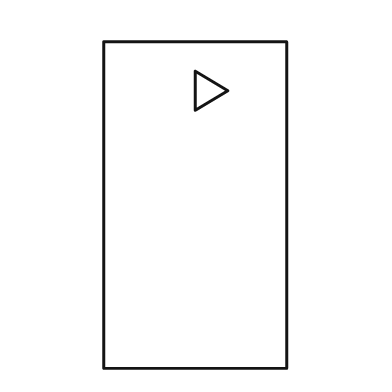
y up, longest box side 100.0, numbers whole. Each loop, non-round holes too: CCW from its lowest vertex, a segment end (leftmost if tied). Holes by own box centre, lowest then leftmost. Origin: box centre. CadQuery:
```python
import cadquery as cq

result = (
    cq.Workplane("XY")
    .moveTo(-28.0, -50.0)
    .lineTo(28.0, -50.0)
    .lineTo(28.0, 50.0)
    .lineTo(-28.0, 50.0)
    .close()
    .moveTo(0.0, 29.0)
    .lineTo(10.0, 35.0)
    .lineTo(0.0, 41.0)
    .close()
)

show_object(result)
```